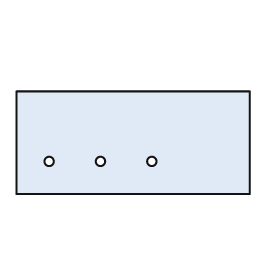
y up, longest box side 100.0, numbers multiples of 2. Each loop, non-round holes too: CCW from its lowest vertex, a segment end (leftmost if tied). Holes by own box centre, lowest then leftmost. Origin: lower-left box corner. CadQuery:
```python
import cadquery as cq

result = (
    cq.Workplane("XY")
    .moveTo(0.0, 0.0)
    .lineTo(100.0, 0.0)
    .lineTo(100.0, 44.0)
    .lineTo(0.0, 44.0)
    .close()
    .moveTo(14.0, 14.0)
    .circle(2.0)
    .moveTo(36.0, 14.0)
    .circle(2.0)
    .moveTo(58.0, 14.0)
    .circle(2.0)
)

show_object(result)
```